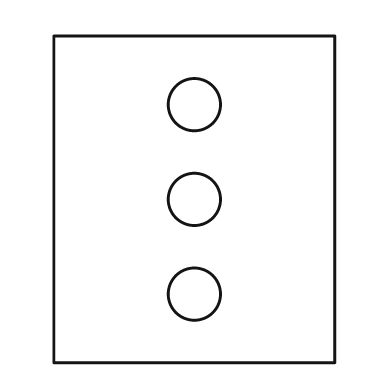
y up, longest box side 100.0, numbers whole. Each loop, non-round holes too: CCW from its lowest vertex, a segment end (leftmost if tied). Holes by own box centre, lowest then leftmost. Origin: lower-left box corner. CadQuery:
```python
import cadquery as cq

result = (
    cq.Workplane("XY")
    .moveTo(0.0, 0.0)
    .lineTo(86.0, 0.0)
    .lineTo(86.0, 100.0)
    .lineTo(0.0, 100.0)
    .close()
    .moveTo(43.0, 21.0)
    .circle(8.0)
    .moveTo(43.0, 50.0)
    .circle(8.0)
    .moveTo(43.0, 79.0)
    .circle(8.0)
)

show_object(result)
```